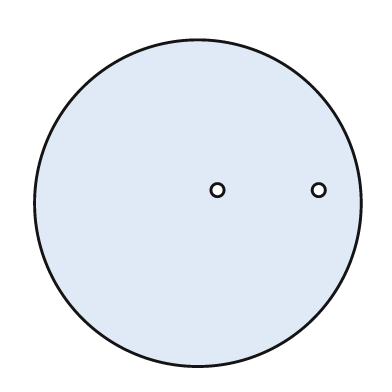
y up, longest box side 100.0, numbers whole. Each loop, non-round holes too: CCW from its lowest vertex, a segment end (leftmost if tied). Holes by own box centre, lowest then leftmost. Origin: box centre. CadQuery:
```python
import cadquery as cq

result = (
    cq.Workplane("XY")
    .moveTo(0.0, 0.0)
    .circle(50.0)
    .moveTo(6.0, 4.0)
    .circle(2.0)
    .moveTo(37.0, 4.0)
    .circle(2.0)
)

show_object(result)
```